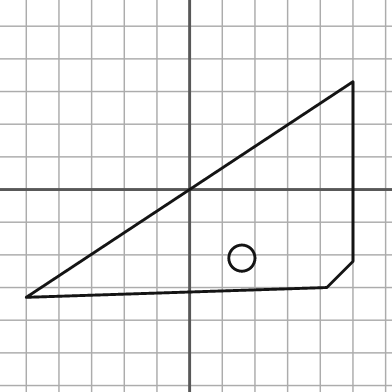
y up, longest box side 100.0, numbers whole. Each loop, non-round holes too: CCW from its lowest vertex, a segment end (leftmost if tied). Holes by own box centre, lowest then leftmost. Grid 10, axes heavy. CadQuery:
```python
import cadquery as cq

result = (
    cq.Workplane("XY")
    .moveTo(-50.0, -33.0)
    .lineTo(42.0, -30.0)
    .lineTo(50.0, -22.0)
    .lineTo(50.0, 33.0)
    .close()
    .moveTo(16.0, -21.0)
    .circle(4.0)
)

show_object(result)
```